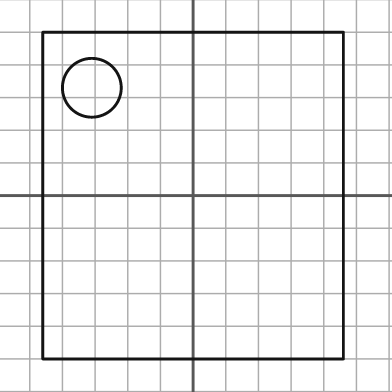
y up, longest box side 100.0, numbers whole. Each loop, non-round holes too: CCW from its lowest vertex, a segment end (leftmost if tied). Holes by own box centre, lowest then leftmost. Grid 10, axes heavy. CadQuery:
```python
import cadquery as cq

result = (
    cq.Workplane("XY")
    .moveTo(-46.0, -50.0)
    .lineTo(46.0, -50.0)
    .lineTo(46.0, 50.0)
    .lineTo(-46.0, 50.0)
    .close()
    .moveTo(-31.0, 33.0)
    .circle(9.0)
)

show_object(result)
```